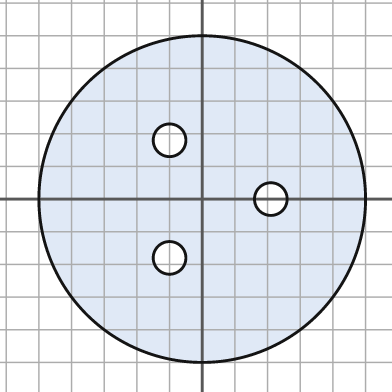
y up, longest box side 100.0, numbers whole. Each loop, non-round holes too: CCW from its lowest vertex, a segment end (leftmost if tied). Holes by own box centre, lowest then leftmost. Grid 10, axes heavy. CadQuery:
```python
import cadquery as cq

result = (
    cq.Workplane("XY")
    .moveTo(0.0, 0.0)
    .circle(50.0)
    .moveTo(-10.0, -18.0)
    .circle(5.0)
    .moveTo(21.0, 0.0)
    .circle(5.0)
    .moveTo(-10.0, 18.0)
    .circle(5.0)
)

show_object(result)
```